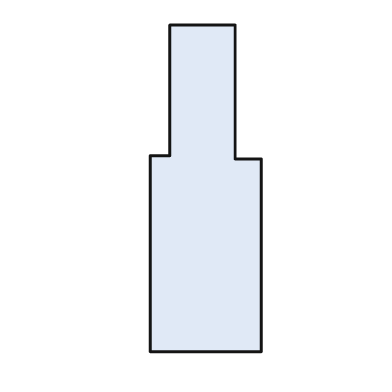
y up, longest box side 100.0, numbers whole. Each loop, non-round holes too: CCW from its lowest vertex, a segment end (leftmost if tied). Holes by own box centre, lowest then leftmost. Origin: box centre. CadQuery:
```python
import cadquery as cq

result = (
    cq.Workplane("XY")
    .moveTo(-17.0, -50.0)
    .lineTo(17.0, -50.0)
    .lineTo(17.0, 9.0)
    .lineTo(9.0, 9.0)
    .lineTo(9.0, 50.0)
    .lineTo(-11.0, 50.0)
    .lineTo(-11.0, 10.0)
    .lineTo(-17.0, 10.0)
    .close()
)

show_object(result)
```